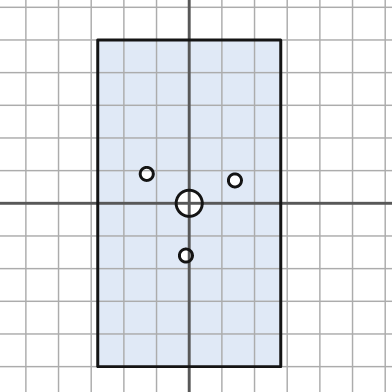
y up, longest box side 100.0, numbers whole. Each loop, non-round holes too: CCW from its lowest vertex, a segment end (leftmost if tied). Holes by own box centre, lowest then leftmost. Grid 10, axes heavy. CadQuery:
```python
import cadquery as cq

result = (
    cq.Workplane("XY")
    .moveTo(-28.0, -50.0)
    .lineTo(28.0, -50.0)
    .lineTo(28.0, 50.0)
    .lineTo(-28.0, 50.0)
    .close()
    .moveTo(-1.0, -16.0)
    .circle(2.0)
    .moveTo(0.0, 0.0)
    .circle(4.0)
    .moveTo(14.0, 7.0)
    .circle(2.0)
    .moveTo(-13.0, 9.0)
    .circle(2.0)
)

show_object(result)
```